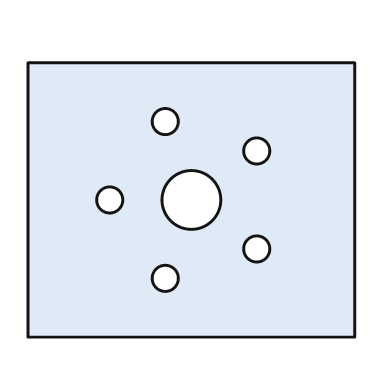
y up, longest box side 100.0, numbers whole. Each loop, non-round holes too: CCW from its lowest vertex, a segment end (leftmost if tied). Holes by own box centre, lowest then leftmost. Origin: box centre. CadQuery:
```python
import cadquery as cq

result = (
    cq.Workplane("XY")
    .moveTo(-50.0, -42.0)
    .lineTo(50.0, -42.0)
    .lineTo(50.0, 42.0)
    .lineTo(-50.0, 42.0)
    .close()
    .moveTo(-8.0, -24.0)
    .circle(4.0)
    .moveTo(20.0, -15.0)
    .circle(4.0)
    .moveTo(-25.0, 0.0)
    .circle(4.0)
    .moveTo(0.0, 0.0)
    .circle(9.0)
    .moveTo(20.0, 15.0)
    .circle(4.0)
    .moveTo(-8.0, 24.0)
    .circle(4.0)
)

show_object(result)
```